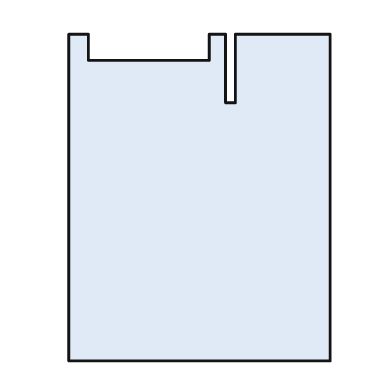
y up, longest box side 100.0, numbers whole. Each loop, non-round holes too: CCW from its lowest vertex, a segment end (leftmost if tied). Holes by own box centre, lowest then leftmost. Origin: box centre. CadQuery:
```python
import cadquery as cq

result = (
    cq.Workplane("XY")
    .moveTo(-40.0, -50.0)
    .lineTo(40.0, -50.0)
    .lineTo(40.0, 50.0)
    .lineTo(11.0, 50.0)
    .lineTo(11.0, 29.0)
    .lineTo(8.0, 29.0)
    .lineTo(8.0, 50.0)
    .lineTo(3.0, 50.0)
    .lineTo(3.0, 42.0)
    .lineTo(-34.0, 42.0)
    .lineTo(-34.0, 50.0)
    .lineTo(-40.0, 50.0)
    .close()
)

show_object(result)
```